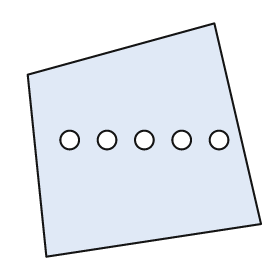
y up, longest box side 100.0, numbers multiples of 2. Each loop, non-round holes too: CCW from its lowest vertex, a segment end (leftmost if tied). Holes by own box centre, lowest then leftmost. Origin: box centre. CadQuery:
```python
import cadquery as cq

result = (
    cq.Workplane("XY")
    .moveTo(-42.0, -50.0)
    .lineTo(50.0, -36.0)
    .lineTo(30.0, 50.0)
    .lineTo(-50.0, 28.0)
    .close()
    .moveTo(-32.0, 0.0)
    .circle(4.0)
    .moveTo(-16.0, 0.0)
    .circle(4.0)
    .moveTo(0.0, 0.0)
    .circle(4.0)
    .moveTo(16.0, 0.0)
    .circle(4.0)
    .moveTo(32.0, 0.0)
    .circle(4.0)
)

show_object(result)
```